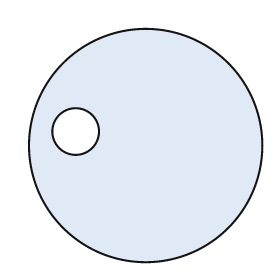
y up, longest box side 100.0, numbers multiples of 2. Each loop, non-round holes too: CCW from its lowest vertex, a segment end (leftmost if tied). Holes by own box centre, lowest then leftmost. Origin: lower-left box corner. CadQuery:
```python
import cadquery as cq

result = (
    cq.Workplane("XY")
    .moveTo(50.0, 50.0)
    .circle(50.0)
    .moveTo(20.0, 56.0)
    .circle(10.0)
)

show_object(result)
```